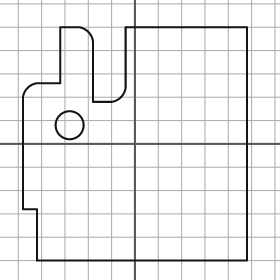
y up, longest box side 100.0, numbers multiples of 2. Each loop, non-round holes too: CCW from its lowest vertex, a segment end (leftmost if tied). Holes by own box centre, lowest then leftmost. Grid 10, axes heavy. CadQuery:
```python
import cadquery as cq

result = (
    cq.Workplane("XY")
    .moveTo(-42.0, -50.0)
    .lineTo(48.0, -50.0)
    .lineTo(48.0, 50.0)
    .lineTo(-4.0, 50.0)
    .lineTo(-4.0, 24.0)
    .threePointArc((-6.0, 20.0), (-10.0, 18.0))
    .lineTo(-18.0, 18.0)
    .lineTo(-18.0, 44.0)
    .threePointArc((-20.0, 48.0), (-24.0, 50.0))
    .lineTo(-32.0, 50.0)
    .lineTo(-32.0, 26.0)
    .lineTo(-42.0, 26.0)
    .threePointArc((-46.0, 24.0), (-48.0, 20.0))
    .lineTo(-48.0, -28.0)
    .lineTo(-42.0, -28.0)
    .close()
    .moveTo(-28.0, 8.0)
    .circle(6.0)
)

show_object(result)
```